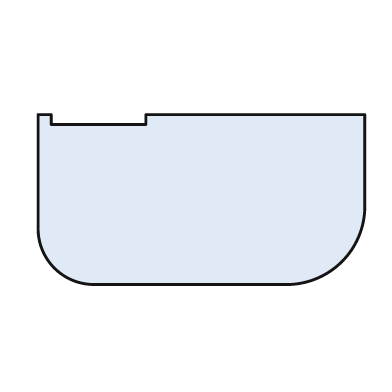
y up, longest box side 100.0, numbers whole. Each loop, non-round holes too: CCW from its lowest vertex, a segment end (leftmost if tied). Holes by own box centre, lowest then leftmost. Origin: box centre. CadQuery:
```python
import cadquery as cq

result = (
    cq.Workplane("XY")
    .moveTo(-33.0, -26.0)
    .lineTo(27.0, -26.0)
    .threePointArc((43.0, -19.0), (50.0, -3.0))
    .lineTo(50.0, 26.0)
    .lineTo(-17.0, 26.0)
    .lineTo(-17.0, 23.0)
    .lineTo(-46.0, 23.0)
    .lineTo(-46.0, 26.0)
    .lineTo(-50.0, 26.0)
    .lineTo(-50.0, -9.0)
    .threePointArc((-45.0, -21.0), (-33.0, -26.0))
    .close()
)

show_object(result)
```